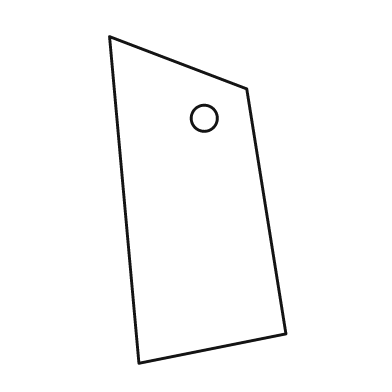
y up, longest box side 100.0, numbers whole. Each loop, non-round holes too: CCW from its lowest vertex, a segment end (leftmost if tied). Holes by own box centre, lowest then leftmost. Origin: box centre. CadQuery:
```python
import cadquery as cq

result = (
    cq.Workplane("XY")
    .moveTo(-18.0, -50.0)
    .lineTo(27.0, -41.0)
    .lineTo(15.0, 34.0)
    .lineTo(-27.0, 50.0)
    .close()
    .moveTo(2.0, 25.0)
    .circle(4.0)
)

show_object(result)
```